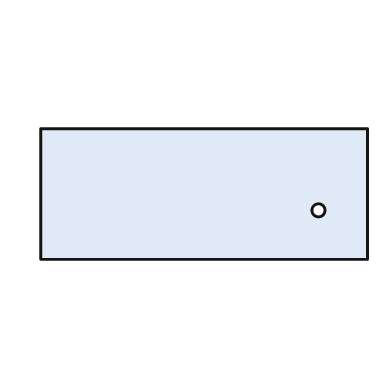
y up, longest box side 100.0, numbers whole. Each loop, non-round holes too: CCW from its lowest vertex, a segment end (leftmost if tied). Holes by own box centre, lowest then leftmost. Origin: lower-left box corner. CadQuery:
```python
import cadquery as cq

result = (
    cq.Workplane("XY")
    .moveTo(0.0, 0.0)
    .lineTo(100.0, 0.0)
    .lineTo(100.0, 40.0)
    .lineTo(0.0, 40.0)
    .close()
    .moveTo(85.0, 15.0)
    .circle(2.0)
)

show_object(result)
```